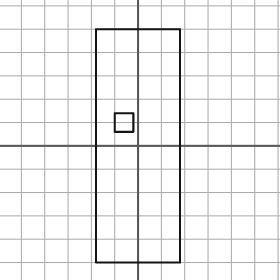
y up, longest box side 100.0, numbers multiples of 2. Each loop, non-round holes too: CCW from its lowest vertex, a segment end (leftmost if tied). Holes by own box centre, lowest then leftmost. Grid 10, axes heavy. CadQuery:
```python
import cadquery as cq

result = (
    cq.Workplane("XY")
    .moveTo(-18.0, -50.0)
    .lineTo(18.0, -50.0)
    .lineTo(18.0, 50.0)
    .lineTo(-18.0, 50.0)
    .close()
    .moveTo(-10.0, 6.0)
    .lineTo(-2.0, 6.0)
    .lineTo(-2.0, 14.0)
    .lineTo(-10.0, 14.0)
    .close()
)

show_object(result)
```